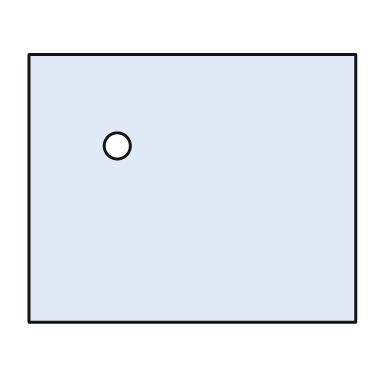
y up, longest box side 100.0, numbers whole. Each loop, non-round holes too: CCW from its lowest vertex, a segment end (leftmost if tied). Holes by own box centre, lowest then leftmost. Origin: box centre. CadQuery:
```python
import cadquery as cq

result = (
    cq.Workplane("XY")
    .moveTo(-50.0, -41.0)
    .lineTo(50.0, -41.0)
    .lineTo(50.0, 41.0)
    .lineTo(-50.0, 41.0)
    .close()
    .moveTo(-23.0, 13.0)
    .circle(4.0)
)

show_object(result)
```